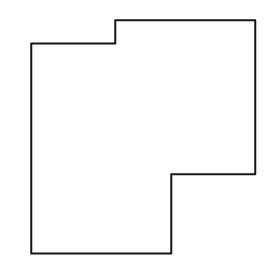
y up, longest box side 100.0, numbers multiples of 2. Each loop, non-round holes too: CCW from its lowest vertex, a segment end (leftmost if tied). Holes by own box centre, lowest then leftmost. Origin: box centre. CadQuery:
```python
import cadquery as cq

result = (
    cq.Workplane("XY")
    .moveTo(-48.0, -50.0)
    .lineTo(12.0, -50.0)
    .lineTo(12.0, -16.0)
    .lineTo(48.0, -16.0)
    .lineTo(48.0, 50.0)
    .lineTo(-12.0, 50.0)
    .lineTo(-12.0, 40.0)
    .lineTo(-48.0, 40.0)
    .close()
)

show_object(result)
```